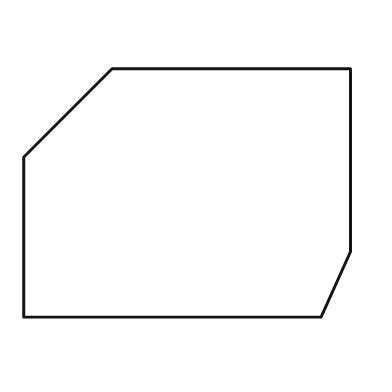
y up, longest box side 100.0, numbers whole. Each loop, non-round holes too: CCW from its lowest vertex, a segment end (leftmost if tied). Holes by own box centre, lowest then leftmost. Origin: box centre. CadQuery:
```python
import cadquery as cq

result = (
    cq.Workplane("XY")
    .moveTo(-50.0, -38.0)
    .lineTo(41.0, -38.0)
    .lineTo(50.0, -18.0)
    .lineTo(50.0, 38.0)
    .lineTo(-23.0, 38.0)
    .lineTo(-50.0, 11.0)
    .close()
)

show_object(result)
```